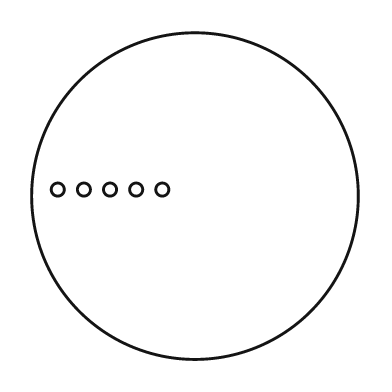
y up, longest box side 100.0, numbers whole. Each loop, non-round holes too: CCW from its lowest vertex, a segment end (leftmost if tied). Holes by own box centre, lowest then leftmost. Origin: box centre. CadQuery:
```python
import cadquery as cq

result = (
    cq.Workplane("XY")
    .moveTo(0.0, 0.0)
    .circle(50.0)
    .moveTo(-42.0, 2.0)
    .circle(2.0)
    .moveTo(-34.0, 2.0)
    .circle(2.0)
    .moveTo(-26.0, 2.0)
    .circle(2.0)
    .moveTo(-18.0, 2.0)
    .circle(2.0)
    .moveTo(-10.0, 2.0)
    .circle(2.0)
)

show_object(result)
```